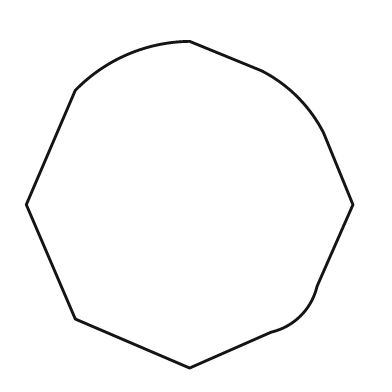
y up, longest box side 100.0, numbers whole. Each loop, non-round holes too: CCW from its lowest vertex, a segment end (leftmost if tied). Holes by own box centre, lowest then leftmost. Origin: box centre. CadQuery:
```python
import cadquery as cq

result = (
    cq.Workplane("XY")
    .moveTo(0.0, -50.0)
    .lineTo(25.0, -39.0)
    .threePointArc((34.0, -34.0), (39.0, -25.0))
    .lineTo(50.0, 0.0)
    .lineTo(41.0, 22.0)
    .threePointArc((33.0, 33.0), (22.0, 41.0))
    .lineTo(0.0, 50.0)
    .threePointArc((-19.0, 46.0), (-35.0, 35.0))
    .lineTo(-50.0, 0.0)
    .lineTo(-35.0, -35.0)
    .close()
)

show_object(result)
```